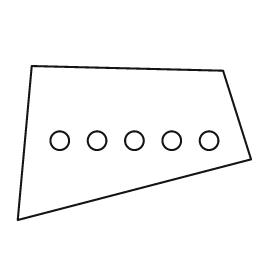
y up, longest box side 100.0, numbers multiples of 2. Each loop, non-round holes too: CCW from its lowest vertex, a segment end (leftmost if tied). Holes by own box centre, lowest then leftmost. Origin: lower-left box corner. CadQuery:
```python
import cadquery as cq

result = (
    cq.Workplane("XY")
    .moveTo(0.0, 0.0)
    .lineTo(100.0, 26.0)
    .lineTo(88.0, 64.0)
    .lineTo(6.0, 66.0)
    .close()
    .moveTo(18.0, 34.0)
    .circle(4.0)
    .moveTo(34.0, 34.0)
    .circle(4.0)
    .moveTo(50.0, 34.0)
    .circle(4.0)
    .moveTo(66.0, 34.0)
    .circle(4.0)
    .moveTo(82.0, 34.0)
    .circle(4.0)
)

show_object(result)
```